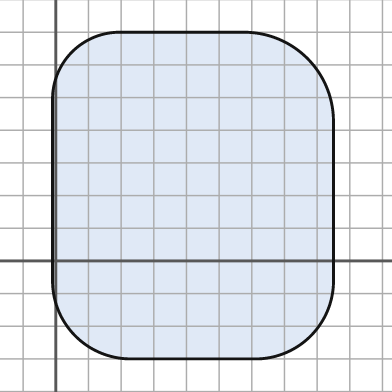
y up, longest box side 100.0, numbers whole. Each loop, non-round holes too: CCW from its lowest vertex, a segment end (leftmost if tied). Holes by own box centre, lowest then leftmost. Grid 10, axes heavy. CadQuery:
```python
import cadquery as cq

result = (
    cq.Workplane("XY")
    .moveTo(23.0, -30.0)
    .lineTo(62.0, -30.0)
    .threePointArc((78.0, -23.0), (85.0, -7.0))
    .lineTo(85.0, 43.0)
    .threePointArc((77.0, 62.0), (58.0, 70.0))
    .lineTo(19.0, 70.0)
    .threePointArc((5.0, 64.0), (-1.0, 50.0))
    .lineTo(-1.0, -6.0)
    .threePointArc((6.0, -23.0), (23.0, -30.0))
    .close()
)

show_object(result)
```